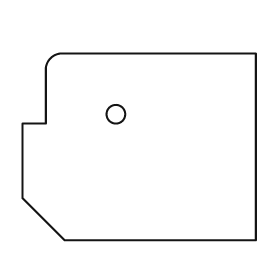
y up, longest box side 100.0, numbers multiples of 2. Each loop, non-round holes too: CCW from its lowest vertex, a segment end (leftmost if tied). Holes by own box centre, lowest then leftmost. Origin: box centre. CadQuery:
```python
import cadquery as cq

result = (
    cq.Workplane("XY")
    .moveTo(-32.0, -40.0)
    .lineTo(50.0, -40.0)
    .lineTo(50.0, 40.0)
    .lineTo(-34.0, 40.0)
    .threePointArc((-38.0, 38.0), (-40.0, 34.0))
    .lineTo(-40.0, 10.0)
    .lineTo(-50.0, 10.0)
    .lineTo(-50.0, -22.0)
    .close()
    .moveTo(-10.0, 14.0)
    .circle(4.0)
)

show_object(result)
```